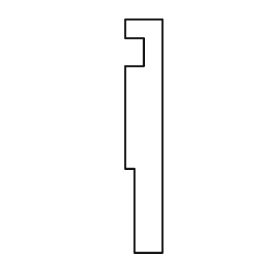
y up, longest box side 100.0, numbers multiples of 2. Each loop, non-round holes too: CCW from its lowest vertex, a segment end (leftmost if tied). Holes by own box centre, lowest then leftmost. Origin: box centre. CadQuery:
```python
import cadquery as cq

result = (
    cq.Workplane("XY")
    .moveTo(-4.0, -50.0)
    .lineTo(8.0, -50.0)
    .lineTo(8.0, 50.0)
    .lineTo(-8.0, 50.0)
    .lineTo(-8.0, 42.0)
    .lineTo(0.0, 42.0)
    .lineTo(0.0, 30.0)
    .lineTo(-8.0, 30.0)
    .lineTo(-8.0, -14.0)
    .lineTo(-4.0, -14.0)
    .close()
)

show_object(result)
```